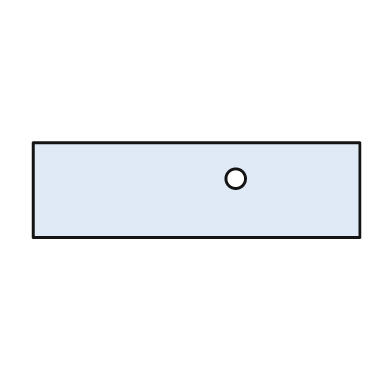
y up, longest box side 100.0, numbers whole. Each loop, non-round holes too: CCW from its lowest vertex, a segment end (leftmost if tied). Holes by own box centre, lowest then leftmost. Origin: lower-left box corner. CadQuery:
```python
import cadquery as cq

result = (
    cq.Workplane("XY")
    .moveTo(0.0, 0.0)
    .lineTo(100.0, 0.0)
    .lineTo(100.0, 29.0)
    .lineTo(0.0, 29.0)
    .close()
    .moveTo(62.0, 18.0)
    .circle(3.0)
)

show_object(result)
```